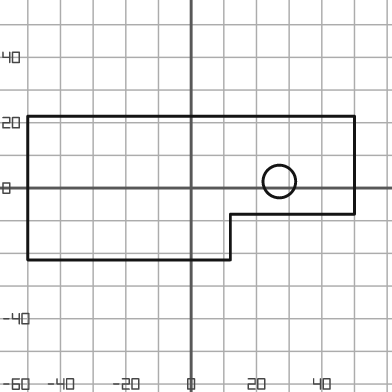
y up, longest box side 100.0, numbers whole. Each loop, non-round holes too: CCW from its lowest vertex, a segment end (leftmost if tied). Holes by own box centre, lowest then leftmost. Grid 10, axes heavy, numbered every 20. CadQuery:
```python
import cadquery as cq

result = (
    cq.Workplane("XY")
    .moveTo(-50.0, -22.0)
    .lineTo(12.0, -22.0)
    .lineTo(12.0, -8.0)
    .lineTo(50.0, -8.0)
    .lineTo(50.0, 22.0)
    .lineTo(-50.0, 22.0)
    .close()
    .moveTo(27.0, 2.0)
    .circle(5.0)
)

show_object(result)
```